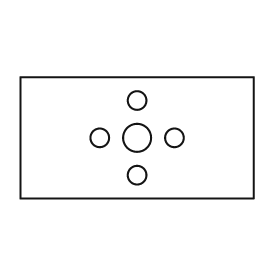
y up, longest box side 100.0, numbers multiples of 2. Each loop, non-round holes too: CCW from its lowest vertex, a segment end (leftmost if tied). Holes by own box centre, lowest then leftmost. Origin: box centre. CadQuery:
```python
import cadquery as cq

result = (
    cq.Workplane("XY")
    .moveTo(-50.0, -26.0)
    .lineTo(50.0, -26.0)
    .lineTo(50.0, 26.0)
    .lineTo(-50.0, 26.0)
    .close()
    .moveTo(0.0, -16.0)
    .circle(4.0)
    .moveTo(-16.0, 0.0)
    .circle(4.0)
    .moveTo(0.0, 0.0)
    .circle(6.0)
    .moveTo(16.0, 0.0)
    .circle(4.0)
    .moveTo(0.0, 16.0)
    .circle(4.0)
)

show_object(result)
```